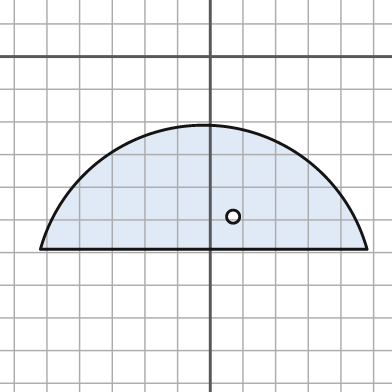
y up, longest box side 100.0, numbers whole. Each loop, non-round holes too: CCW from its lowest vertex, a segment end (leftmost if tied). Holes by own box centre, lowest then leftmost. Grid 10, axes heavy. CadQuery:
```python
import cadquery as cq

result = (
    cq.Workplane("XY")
    .moveTo(-52.0, -59.0)
    .lineTo(48.0, -59.0)
    .threePointArc((-2.0, -21.0), (-52.0, -59.0))
    .close()
    .moveTo(7.0, -49.0)
    .circle(2.0)
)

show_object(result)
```